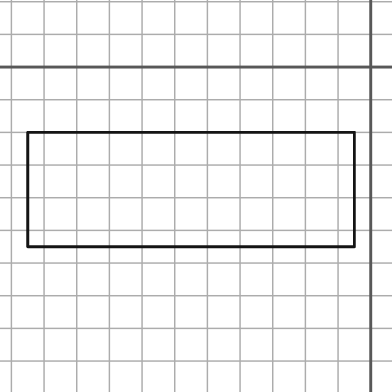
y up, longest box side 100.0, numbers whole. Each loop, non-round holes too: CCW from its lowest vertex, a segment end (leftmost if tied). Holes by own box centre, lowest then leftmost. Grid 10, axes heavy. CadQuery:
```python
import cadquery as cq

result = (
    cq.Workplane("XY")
    .moveTo(-105.0, -55.0)
    .lineTo(-5.0, -55.0)
    .lineTo(-5.0, -20.0)
    .lineTo(-105.0, -20.0)
    .close()
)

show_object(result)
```